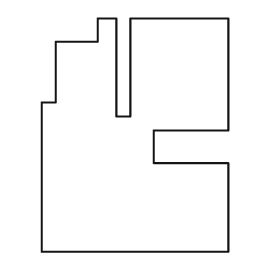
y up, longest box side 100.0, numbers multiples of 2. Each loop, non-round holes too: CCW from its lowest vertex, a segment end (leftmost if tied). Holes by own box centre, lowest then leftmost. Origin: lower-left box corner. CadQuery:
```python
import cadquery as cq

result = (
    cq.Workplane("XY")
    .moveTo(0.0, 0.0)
    .lineTo(80.0, 0.0)
    .lineTo(80.0, 38.0)
    .lineTo(48.0, 38.0)
    .lineTo(48.0, 52.0)
    .lineTo(80.0, 52.0)
    .lineTo(80.0, 100.0)
    .lineTo(38.0, 100.0)
    .lineTo(38.0, 58.0)
    .lineTo(32.0, 58.0)
    .lineTo(32.0, 100.0)
    .lineTo(24.0, 100.0)
    .lineTo(24.0, 90.0)
    .lineTo(6.0, 90.0)
    .lineTo(6.0, 64.0)
    .lineTo(0.0, 64.0)
    .close()
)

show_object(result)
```